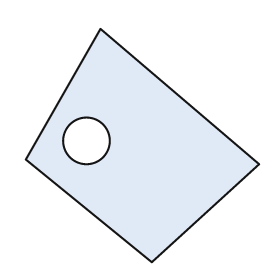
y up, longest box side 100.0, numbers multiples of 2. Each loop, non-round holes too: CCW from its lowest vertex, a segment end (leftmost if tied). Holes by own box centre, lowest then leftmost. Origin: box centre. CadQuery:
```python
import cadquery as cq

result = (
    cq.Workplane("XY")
    .moveTo(4.0, -50.0)
    .lineTo(50.0, -8.0)
    .lineTo(-18.0, 50.0)
    .lineTo(-50.0, -6.0)
    .close()
    .moveTo(-24.0, 2.0)
    .circle(10.0)
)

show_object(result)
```